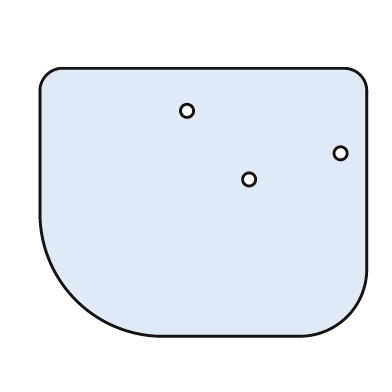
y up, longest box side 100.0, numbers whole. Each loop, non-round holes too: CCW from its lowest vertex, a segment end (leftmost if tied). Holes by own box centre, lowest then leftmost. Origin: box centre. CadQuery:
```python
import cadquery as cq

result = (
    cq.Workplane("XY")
    .moveTo(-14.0, -41.0)
    .lineTo(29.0, -41.0)
    .threePointArc((44.0, -35.0), (50.0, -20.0))
    .lineTo(50.0, 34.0)
    .threePointArc((48.0, 39.0), (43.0, 41.0))
    .lineTo(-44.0, 41.0)
    .threePointArc((-48.0, 39.0), (-50.0, 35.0))
    .lineTo(-50.0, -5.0)
    .threePointArc((-39.0, -30.0), (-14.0, -41.0))
    .close()
    .moveTo(14.0, 7.0)
    .circle(2.0)
    .moveTo(42.0, 15.0)
    .circle(2.0)
    .moveTo(-5.0, 28.0)
    .circle(2.0)
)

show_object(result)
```